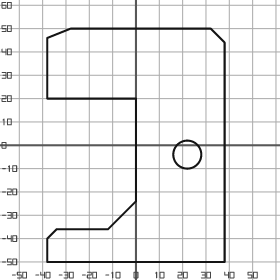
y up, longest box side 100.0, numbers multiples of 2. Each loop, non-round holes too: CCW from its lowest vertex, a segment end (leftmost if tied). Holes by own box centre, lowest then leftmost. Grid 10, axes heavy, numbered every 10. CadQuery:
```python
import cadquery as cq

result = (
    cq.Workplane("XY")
    .moveTo(-38.0, -50.0)
    .lineTo(38.0, -50.0)
    .lineTo(38.0, 44.0)
    .lineTo(32.0, 50.0)
    .lineTo(-28.0, 50.0)
    .lineTo(-38.0, 46.0)
    .lineTo(-38.0, 20.0)
    .lineTo(0.0, 20.0)
    .lineTo(0.0, -24.0)
    .lineTo(-12.0, -36.0)
    .lineTo(-34.0, -36.0)
    .lineTo(-38.0, -40.0)
    .close()
    .moveTo(22.0, -4.0)
    .circle(6.0)
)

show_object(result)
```